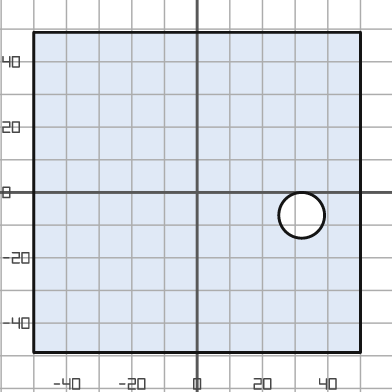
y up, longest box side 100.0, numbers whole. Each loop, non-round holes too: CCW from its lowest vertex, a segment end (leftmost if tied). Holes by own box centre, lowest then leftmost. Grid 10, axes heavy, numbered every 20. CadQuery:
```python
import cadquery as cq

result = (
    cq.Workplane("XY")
    .moveTo(-50.0, -49.0)
    .lineTo(50.0, -49.0)
    .lineTo(50.0, 49.0)
    .lineTo(-50.0, 49.0)
    .close()
    .moveTo(32.0, -7.0)
    .circle(7.0)
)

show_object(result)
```